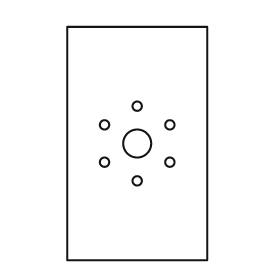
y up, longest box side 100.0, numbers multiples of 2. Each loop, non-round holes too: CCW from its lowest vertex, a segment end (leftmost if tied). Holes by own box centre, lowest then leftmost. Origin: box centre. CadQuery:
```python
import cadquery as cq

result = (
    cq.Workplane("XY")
    .moveTo(-30.0, -50.0)
    .lineTo(30.0, -50.0)
    .lineTo(30.0, 50.0)
    .lineTo(-30.0, 50.0)
    .close()
    .moveTo(0.0, -16.0)
    .circle(2.0)
    .moveTo(-14.0, -8.0)
    .circle(2.0)
    .moveTo(14.0, -8.0)
    .circle(2.0)
    .moveTo(0.0, 0.0)
    .circle(6.0)
    .moveTo(-14.0, 8.0)
    .circle(2.0)
    .moveTo(14.0, 8.0)
    .circle(2.0)
    .moveTo(0.0, 16.0)
    .circle(2.0)
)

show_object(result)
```